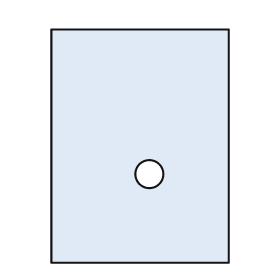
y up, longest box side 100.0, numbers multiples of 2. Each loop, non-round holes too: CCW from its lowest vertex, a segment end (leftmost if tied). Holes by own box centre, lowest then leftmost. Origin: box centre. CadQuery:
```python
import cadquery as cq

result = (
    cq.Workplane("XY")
    .moveTo(-38.0, -50.0)
    .lineTo(38.0, -50.0)
    .lineTo(38.0, 50.0)
    .lineTo(-38.0, 50.0)
    .close()
    .moveTo(4.0, -12.0)
    .circle(6.0)
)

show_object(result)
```